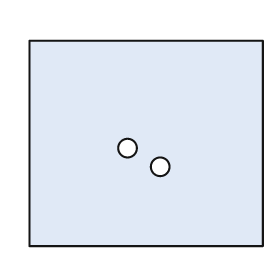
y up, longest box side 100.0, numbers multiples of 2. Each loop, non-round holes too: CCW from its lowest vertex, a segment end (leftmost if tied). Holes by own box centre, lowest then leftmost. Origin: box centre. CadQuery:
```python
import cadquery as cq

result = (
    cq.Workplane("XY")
    .moveTo(-50.0, -44.0)
    .lineTo(50.0, -44.0)
    .lineTo(50.0, 44.0)
    .lineTo(-50.0, 44.0)
    .close()
    .moveTo(6.0, -10.0)
    .circle(4.0)
    .moveTo(-8.0, -2.0)
    .circle(4.0)
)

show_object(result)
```